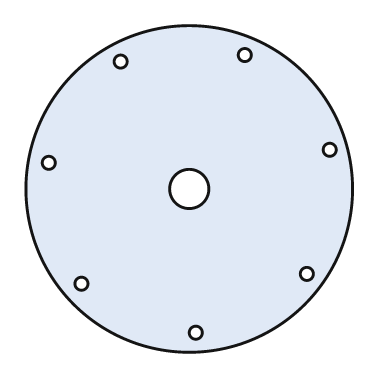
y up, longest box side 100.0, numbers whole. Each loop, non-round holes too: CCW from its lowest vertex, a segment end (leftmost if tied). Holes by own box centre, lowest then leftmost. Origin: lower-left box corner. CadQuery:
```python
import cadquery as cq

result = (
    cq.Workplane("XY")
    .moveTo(50.0, 50.0)
    .circle(50.0)
    .moveTo(52.0, 6.0)
    .circle(2.0)
    .moveTo(17.0, 21.0)
    .circle(2.0)
    .moveTo(86.0, 24.0)
    .circle(2.0)
    .moveTo(50.0, 50.0)
    .circle(6.0)
    .moveTo(7.0, 58.0)
    .circle(2.0)
    .moveTo(93.0, 62.0)
    .circle(2.0)
    .moveTo(29.0, 89.0)
    .circle(2.0)
    .moveTo(67.0, 91.0)
    .circle(2.0)
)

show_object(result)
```